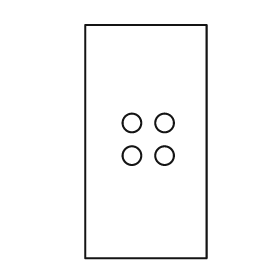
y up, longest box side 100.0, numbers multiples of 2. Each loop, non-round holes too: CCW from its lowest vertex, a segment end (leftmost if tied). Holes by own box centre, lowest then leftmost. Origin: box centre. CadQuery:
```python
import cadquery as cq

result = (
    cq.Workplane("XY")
    .moveTo(-26.0, -50.0)
    .lineTo(26.0, -50.0)
    .lineTo(26.0, 50.0)
    .lineTo(-26.0, 50.0)
    .close()
    .moveTo(-6.0, -6.0)
    .circle(4.0)
    .moveTo(8.0, -6.0)
    .circle(4.0)
    .moveTo(-6.0, 8.0)
    .circle(4.0)
    .moveTo(8.0, 8.0)
    .circle(4.0)
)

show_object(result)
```